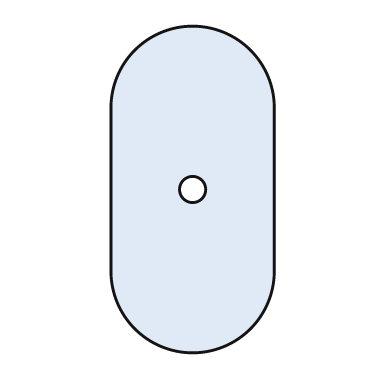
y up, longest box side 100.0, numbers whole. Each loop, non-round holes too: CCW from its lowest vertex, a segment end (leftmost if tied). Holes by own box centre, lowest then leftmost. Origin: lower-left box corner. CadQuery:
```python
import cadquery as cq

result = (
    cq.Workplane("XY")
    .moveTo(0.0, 25.0)
    .threePointArc((25.0, 0.0), (50.0, 25.0))
    .lineTo(50.0, 75.0)
    .threePointArc((25.0, 100.0), (0.0, 75.0))
    .close()
    .moveTo(25.0, 50.0)
    .circle(4.0)
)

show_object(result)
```